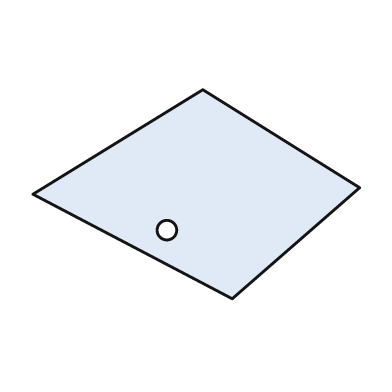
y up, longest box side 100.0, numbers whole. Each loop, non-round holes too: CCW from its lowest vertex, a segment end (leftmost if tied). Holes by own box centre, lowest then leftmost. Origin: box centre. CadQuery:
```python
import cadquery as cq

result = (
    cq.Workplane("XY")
    .moveTo(11.0, -32.0)
    .lineTo(50.0, 2.0)
    .lineTo(2.0, 32.0)
    .lineTo(-50.0, 0.0)
    .close()
    .moveTo(-9.0, -11.0)
    .circle(3.0)
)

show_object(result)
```